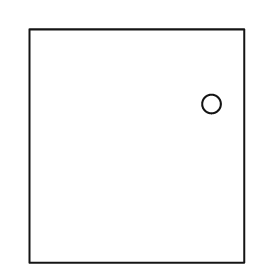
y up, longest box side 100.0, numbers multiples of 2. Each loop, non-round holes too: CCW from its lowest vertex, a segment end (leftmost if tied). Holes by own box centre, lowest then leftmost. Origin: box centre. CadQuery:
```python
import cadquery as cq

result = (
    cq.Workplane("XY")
    .moveTo(-46.0, -50.0)
    .lineTo(46.0, -50.0)
    .lineTo(46.0, 50.0)
    .lineTo(-46.0, 50.0)
    .close()
    .moveTo(32.0, 18.0)
    .circle(4.0)
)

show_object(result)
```